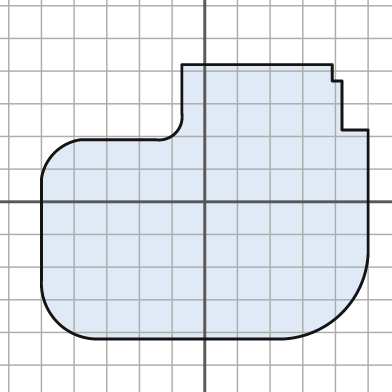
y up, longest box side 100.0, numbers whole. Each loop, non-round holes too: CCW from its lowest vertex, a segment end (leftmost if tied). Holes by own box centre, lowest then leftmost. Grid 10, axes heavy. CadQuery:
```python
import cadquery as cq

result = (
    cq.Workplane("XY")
    .moveTo(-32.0, -42.0)
    .lineTo(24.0, -42.0)
    .threePointArc((42.0, -34.0), (50.0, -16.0))
    .lineTo(50.0, 22.0)
    .lineTo(42.0, 22.0)
    .lineTo(42.0, 37.0)
    .lineTo(39.0, 37.0)
    .lineTo(39.0, 42.0)
    .lineTo(-7.0, 42.0)
    .lineTo(-7.0, 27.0)
    .threePointArc((-9.0, 21.0), (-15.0, 19.0))
    .lineTo(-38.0, 19.0)
    .threePointArc((-46.0, 15.0), (-50.0, 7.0))
    .lineTo(-50.0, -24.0)
    .threePointArc((-45.0, -37.0), (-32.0, -42.0))
    .close()
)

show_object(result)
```